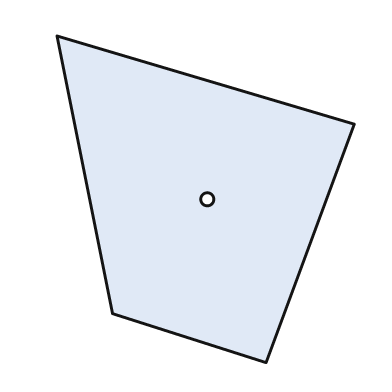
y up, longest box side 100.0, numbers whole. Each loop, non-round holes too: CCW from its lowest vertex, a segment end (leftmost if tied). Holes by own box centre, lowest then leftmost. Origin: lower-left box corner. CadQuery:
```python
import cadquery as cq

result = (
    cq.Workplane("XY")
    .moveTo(64.0, 0.0)
    .lineTo(91.0, 73.0)
    .lineTo(0.0, 100.0)
    .lineTo(17.0, 15.0)
    .close()
    .moveTo(46.0, 50.0)
    .circle(2.0)
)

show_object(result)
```